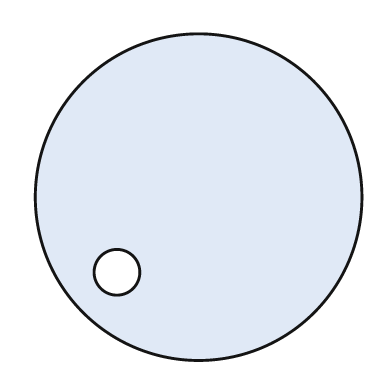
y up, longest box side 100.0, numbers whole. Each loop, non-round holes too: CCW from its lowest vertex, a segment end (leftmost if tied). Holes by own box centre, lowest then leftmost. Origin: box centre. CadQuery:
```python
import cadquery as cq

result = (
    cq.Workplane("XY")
    .moveTo(0.0, 0.0)
    .circle(50.0)
    .moveTo(-25.0, -23.0)
    .circle(7.0)
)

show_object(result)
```